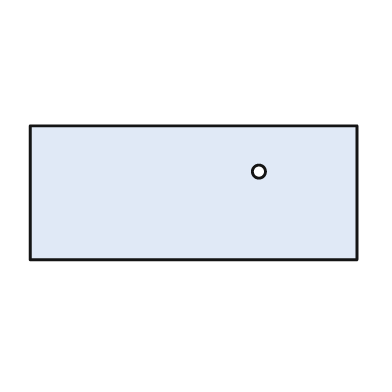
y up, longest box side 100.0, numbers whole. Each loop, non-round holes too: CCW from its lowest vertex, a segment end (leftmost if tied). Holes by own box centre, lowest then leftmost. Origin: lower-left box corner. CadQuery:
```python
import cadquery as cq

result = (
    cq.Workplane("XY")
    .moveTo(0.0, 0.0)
    .lineTo(100.0, 0.0)
    .lineTo(100.0, 41.0)
    .lineTo(0.0, 41.0)
    .close()
    .moveTo(70.0, 27.0)
    .circle(2.0)
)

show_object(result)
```